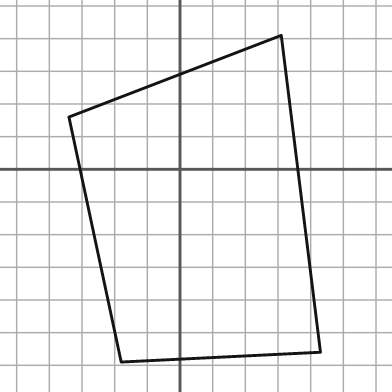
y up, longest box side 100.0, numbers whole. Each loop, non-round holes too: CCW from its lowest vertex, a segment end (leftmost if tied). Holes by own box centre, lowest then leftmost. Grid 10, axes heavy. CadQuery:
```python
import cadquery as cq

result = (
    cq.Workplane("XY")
    .moveTo(-18.0, -59.0)
    .lineTo(43.0, -56.0)
    .lineTo(31.0, 41.0)
    .lineTo(-34.0, 16.0)
    .close()
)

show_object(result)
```